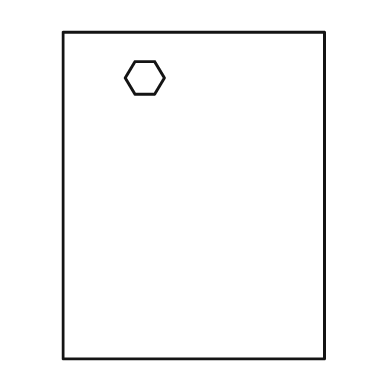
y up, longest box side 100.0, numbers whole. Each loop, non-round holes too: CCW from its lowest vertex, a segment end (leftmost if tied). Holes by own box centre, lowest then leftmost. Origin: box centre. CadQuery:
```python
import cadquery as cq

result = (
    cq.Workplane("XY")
    .moveTo(-40.0, -50.0)
    .lineTo(40.0, -50.0)
    .lineTo(40.0, 50.0)
    .lineTo(-40.0, 50.0)
    .close()
    .moveTo(-18.0, 31.0)
    .lineTo(-12.0, 31.0)
    .lineTo(-9.0, 36.0)
    .lineTo(-12.0, 41.0)
    .lineTo(-18.0, 41.0)
    .lineTo(-21.0, 36.0)
    .close()
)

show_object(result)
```